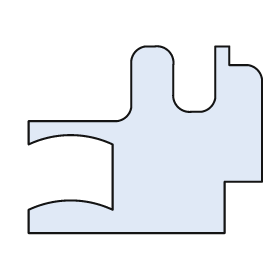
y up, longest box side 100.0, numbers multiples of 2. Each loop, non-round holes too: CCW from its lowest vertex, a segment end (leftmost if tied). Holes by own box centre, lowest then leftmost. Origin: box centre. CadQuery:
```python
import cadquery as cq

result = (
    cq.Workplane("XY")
    .moveTo(-50.0, -40.0)
    .lineTo(34.0, -40.0)
    .lineTo(34.0, -18.0)
    .lineTo(50.0, -18.0)
    .lineTo(50.0, 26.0)
    .threePointArc((48.0, 30.0), (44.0, 32.0))
    .lineTo(36.0, 32.0)
    .lineTo(36.0, 40.0)
    .lineTo(30.0, 40.0)
    .lineTo(30.0, 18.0)
    .threePointArc((28.0, 14.0), (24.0, 12.0))
    .lineTo(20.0, 12.0)
    .threePointArc((14.0, 14.0), (12.0, 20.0))
    .lineTo(12.0, 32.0)
    .threePointArc((10.0, 38.0), (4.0, 40.0))
    .lineTo(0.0, 40.0)
    .threePointArc((-4.0, 38.0), (-6.0, 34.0))
    .lineTo(-6.0, 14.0)
    .threePointArc((-8.0, 10.0), (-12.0, 8.0))
    .lineTo(-50.0, 8.0)
    .lineTo(-50.0, -2.0)
    .threePointArc((-32.0, 2.0), (-14.0, -2.0))
    .lineTo(-14.0, -30.0)
    .threePointArc((-32.0, -26.0), (-50.0, -30.0))
    .close()
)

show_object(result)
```